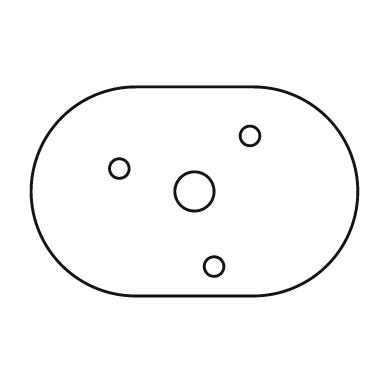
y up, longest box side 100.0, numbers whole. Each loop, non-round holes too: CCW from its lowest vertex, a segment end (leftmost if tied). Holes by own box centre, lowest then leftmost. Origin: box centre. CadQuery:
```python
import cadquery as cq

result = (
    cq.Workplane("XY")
    .moveTo(-18.0, -32.0)
    .lineTo(18.0, -32.0)
    .threePointArc((50.0, 0.0), (18.0, 32.0))
    .lineTo(-18.0, 32.0)
    .threePointArc((-50.0, 0.0), (-18.0, -32.0))
    .close()
    .moveTo(6.0, -23.0)
    .circle(3.0)
    .moveTo(0.0, 0.0)
    .circle(6.0)
    .moveTo(-23.0, 7.0)
    .circle(3.0)
    .moveTo(17.0, 17.0)
    .circle(3.0)
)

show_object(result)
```